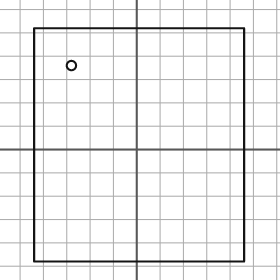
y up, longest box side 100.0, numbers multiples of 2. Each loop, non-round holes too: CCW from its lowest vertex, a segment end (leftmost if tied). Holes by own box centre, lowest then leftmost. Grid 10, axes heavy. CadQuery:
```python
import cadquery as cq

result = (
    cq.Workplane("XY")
    .moveTo(-44.0, -48.0)
    .lineTo(46.0, -48.0)
    .lineTo(46.0, 52.0)
    .lineTo(-44.0, 52.0)
    .close()
    .moveTo(-28.0, 36.0)
    .circle(2.0)
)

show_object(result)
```